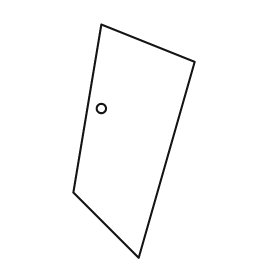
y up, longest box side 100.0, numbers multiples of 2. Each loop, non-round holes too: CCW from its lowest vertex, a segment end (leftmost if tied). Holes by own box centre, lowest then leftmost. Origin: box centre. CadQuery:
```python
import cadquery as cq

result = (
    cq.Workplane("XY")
    .moveTo(2.0, -50.0)
    .lineTo(26.0, 34.0)
    .lineTo(-14.0, 50.0)
    .lineTo(-26.0, -22.0)
    .close()
    .moveTo(-14.0, 14.0)
    .circle(2.0)
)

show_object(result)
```